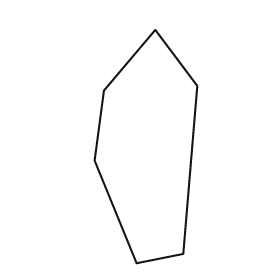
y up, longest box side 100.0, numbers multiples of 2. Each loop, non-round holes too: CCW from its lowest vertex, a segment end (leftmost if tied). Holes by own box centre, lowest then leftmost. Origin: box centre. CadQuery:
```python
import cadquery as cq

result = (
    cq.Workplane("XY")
    .moveTo(-4.0, -50.0)
    .lineTo(16.0, -46.0)
    .lineTo(22.0, 26.0)
    .lineTo(4.0, 50.0)
    .lineTo(-18.0, 24.0)
    .lineTo(-22.0, -6.0)
    .close()
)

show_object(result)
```